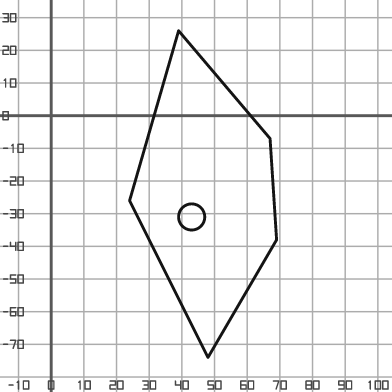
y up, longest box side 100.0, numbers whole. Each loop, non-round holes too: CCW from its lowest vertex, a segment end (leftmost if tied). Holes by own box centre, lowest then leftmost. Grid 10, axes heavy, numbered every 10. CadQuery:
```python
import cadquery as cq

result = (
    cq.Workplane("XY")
    .moveTo(48.0, -74.0)
    .lineTo(69.0, -38.0)
    .lineTo(67.0, -7.0)
    .lineTo(39.0, 26.0)
    .lineTo(24.0, -26.0)
    .close()
    .moveTo(43.0, -31.0)
    .circle(4.0)
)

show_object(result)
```